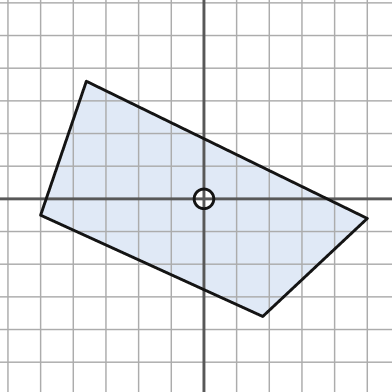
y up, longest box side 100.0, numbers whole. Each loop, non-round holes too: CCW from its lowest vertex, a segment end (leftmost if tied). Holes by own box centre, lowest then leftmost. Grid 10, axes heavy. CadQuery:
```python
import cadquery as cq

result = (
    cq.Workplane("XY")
    .moveTo(18.0, -36.0)
    .lineTo(50.0, -6.0)
    .lineTo(-36.0, 36.0)
    .lineTo(-50.0, -5.0)
    .close()
    .moveTo(0.0, 0.0)
    .circle(3.0)
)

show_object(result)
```